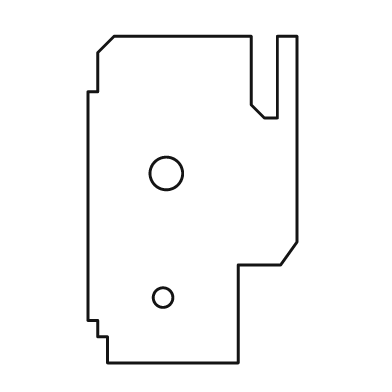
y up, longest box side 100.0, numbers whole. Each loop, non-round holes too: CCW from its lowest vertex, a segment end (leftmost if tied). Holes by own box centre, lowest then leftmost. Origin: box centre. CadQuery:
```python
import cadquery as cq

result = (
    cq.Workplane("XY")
    .moveTo(-26.0, -50.0)
    .lineTo(14.0, -50.0)
    .lineTo(14.0, -20.0)
    .lineTo(27.0, -20.0)
    .lineTo(32.0, -13.0)
    .lineTo(32.0, 50.0)
    .lineTo(26.0, 50.0)
    .lineTo(26.0, 25.0)
    .lineTo(22.0, 25.0)
    .lineTo(18.0, 29.0)
    .lineTo(18.0, 50.0)
    .lineTo(-24.0, 50.0)
    .lineTo(-29.0, 45.0)
    .lineTo(-29.0, 33.0)
    .lineTo(-32.0, 33.0)
    .lineTo(-32.0, -37.0)
    .lineTo(-29.0, -37.0)
    .lineTo(-29.0, -42.0)
    .lineTo(-26.0, -42.0)
    .close()
    .moveTo(-9.0, -30.0)
    .circle(3.0)
    .moveTo(-8.0, 8.0)
    .circle(5.0)
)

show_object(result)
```